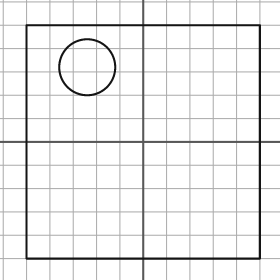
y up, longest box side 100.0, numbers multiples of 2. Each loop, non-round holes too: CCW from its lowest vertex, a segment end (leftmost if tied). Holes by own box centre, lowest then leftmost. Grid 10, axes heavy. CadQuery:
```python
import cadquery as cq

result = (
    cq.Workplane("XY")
    .moveTo(-50.0, -50.0)
    .lineTo(50.0, -50.0)
    .lineTo(50.0, 50.0)
    .lineTo(-50.0, 50.0)
    .close()
    .moveTo(-24.0, 32.0)
    .circle(12.0)
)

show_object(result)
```